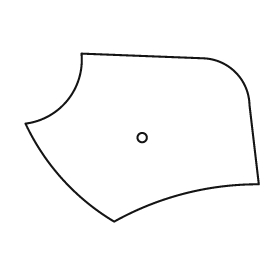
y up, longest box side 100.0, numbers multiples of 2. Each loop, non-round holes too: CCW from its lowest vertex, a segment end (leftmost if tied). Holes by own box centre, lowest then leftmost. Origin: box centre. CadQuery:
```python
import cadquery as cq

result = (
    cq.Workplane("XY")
    .moveTo(-12.0, -36.0)
    .threePointArc((18.0, -24.0), (50.0, -20.0))
    .lineTo(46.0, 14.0)
    .threePointArc((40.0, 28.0), (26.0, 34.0))
    .lineTo(-26.0, 36.0)
    .threePointArc((-32.0, 16.0), (-50.0, 6.0))
    .threePointArc((-34.0, -18.0), (-12.0, -36.0))
    .close()
    .moveTo(0.0, 0.0)
    .circle(2.0)
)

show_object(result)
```